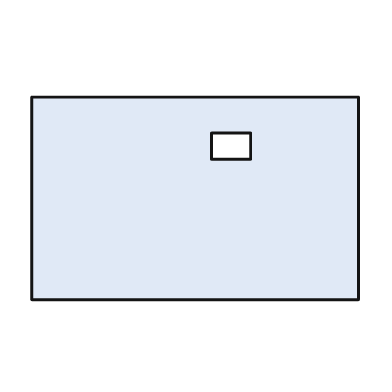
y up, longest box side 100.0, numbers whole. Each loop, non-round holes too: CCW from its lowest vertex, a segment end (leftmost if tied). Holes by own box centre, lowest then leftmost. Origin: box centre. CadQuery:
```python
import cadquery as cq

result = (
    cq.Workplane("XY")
    .moveTo(-50.0, -31.0)
    .lineTo(50.0, -31.0)
    .lineTo(50.0, 31.0)
    .lineTo(-50.0, 31.0)
    .close()
    .moveTo(5.0, 12.0)
    .lineTo(17.0, 12.0)
    .lineTo(17.0, 20.0)
    .lineTo(5.0, 20.0)
    .close()
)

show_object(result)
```